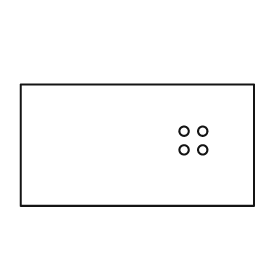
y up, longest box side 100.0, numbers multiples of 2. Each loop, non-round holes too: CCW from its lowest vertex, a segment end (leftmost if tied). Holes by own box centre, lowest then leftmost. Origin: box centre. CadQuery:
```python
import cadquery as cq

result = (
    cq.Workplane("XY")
    .moveTo(-50.0, -26.0)
    .lineTo(50.0, -26.0)
    .lineTo(50.0, 26.0)
    .lineTo(-50.0, 26.0)
    .close()
    .moveTo(20.0, -2.0)
    .circle(2.0)
    .moveTo(28.0, -2.0)
    .circle(2.0)
    .moveTo(20.0, 6.0)
    .circle(2.0)
    .moveTo(28.0, 6.0)
    .circle(2.0)
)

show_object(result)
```